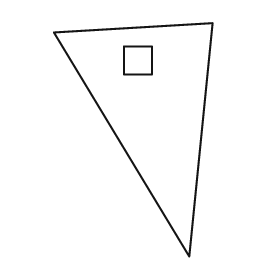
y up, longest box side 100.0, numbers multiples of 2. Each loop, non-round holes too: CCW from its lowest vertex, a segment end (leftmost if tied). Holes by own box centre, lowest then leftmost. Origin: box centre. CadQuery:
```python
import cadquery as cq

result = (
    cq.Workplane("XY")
    .moveTo(24.0, -50.0)
    .lineTo(34.0, 50.0)
    .lineTo(-34.0, 46.0)
    .close()
    .moveTo(-4.0, 28.0)
    .lineTo(8.0, 28.0)
    .lineTo(8.0, 40.0)
    .lineTo(-4.0, 40.0)
    .close()
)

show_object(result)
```